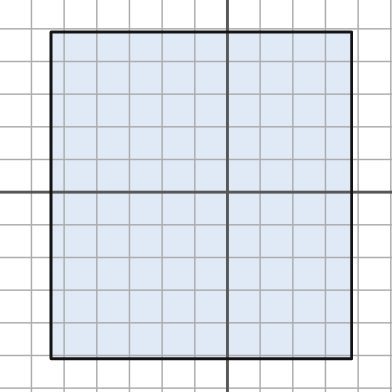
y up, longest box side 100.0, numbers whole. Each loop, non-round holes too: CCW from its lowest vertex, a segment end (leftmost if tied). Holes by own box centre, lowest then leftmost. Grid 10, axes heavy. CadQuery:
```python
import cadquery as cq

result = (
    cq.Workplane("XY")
    .moveTo(-54.0, -51.0)
    .lineTo(38.0, -51.0)
    .lineTo(38.0, 49.0)
    .lineTo(-54.0, 49.0)
    .close()
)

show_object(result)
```